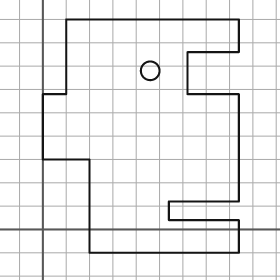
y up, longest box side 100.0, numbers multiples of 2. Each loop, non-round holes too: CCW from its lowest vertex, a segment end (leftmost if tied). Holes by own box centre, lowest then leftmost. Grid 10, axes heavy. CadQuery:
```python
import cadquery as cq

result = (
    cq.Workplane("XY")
    .moveTo(20.0, -10.0)
    .lineTo(84.0, -10.0)
    .lineTo(84.0, 4.0)
    .lineTo(54.0, 4.0)
    .lineTo(54.0, 12.0)
    .lineTo(84.0, 12.0)
    .lineTo(84.0, 58.0)
    .lineTo(62.0, 58.0)
    .lineTo(62.0, 76.0)
    .lineTo(84.0, 76.0)
    .lineTo(84.0, 90.0)
    .lineTo(10.0, 90.0)
    .lineTo(10.0, 58.0)
    .lineTo(0.0, 58.0)
    .lineTo(0.0, 30.0)
    .lineTo(20.0, 30.0)
    .close()
    .moveTo(46.0, 68.0)
    .circle(4.0)
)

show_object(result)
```